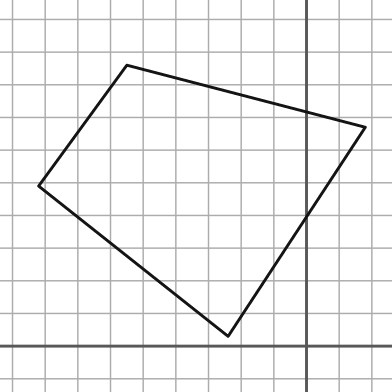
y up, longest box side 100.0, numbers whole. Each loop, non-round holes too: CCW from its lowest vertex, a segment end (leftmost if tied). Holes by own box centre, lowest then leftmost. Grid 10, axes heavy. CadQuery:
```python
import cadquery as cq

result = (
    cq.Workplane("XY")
    .moveTo(-24.0, 3.0)
    .lineTo(18.0, 67.0)
    .lineTo(-55.0, 86.0)
    .lineTo(-82.0, 49.0)
    .close()
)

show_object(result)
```